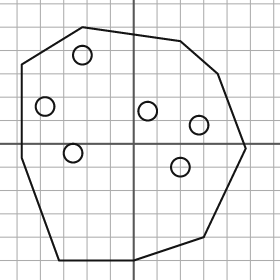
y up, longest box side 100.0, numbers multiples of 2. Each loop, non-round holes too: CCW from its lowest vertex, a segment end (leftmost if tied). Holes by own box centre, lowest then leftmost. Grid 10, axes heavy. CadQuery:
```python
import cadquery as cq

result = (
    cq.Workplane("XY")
    .moveTo(-32.0, -50.0)
    .lineTo(0.0, -50.0)
    .lineTo(30.0, -40.0)
    .lineTo(48.0, -2.0)
    .lineTo(36.0, 30.0)
    .lineTo(20.0, 44.0)
    .lineTo(-22.0, 50.0)
    .lineTo(-48.0, 34.0)
    .lineTo(-48.0, -6.0)
    .close()
    .moveTo(20.0, -10.0)
    .circle(4.0)
    .moveTo(-26.0, -4.0)
    .circle(4.0)
    .moveTo(28.0, 8.0)
    .circle(4.0)
    .moveTo(6.0, 14.0)
    .circle(4.0)
    .moveTo(-38.0, 16.0)
    .circle(4.0)
    .moveTo(-22.0, 38.0)
    .circle(4.0)
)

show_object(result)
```